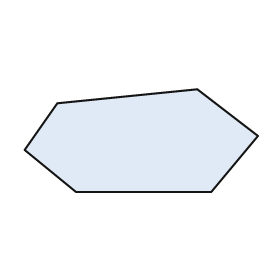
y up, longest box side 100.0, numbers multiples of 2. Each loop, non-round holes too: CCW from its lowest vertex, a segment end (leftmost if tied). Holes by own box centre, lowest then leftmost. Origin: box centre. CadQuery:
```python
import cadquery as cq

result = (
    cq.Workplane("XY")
    .moveTo(-28.0, -22.0)
    .lineTo(30.0, -22.0)
    .lineTo(50.0, 2.0)
    .lineTo(24.0, 22.0)
    .lineTo(-36.0, 16.0)
    .lineTo(-50.0, -4.0)
    .close()
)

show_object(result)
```